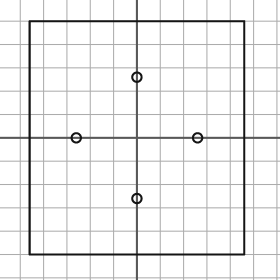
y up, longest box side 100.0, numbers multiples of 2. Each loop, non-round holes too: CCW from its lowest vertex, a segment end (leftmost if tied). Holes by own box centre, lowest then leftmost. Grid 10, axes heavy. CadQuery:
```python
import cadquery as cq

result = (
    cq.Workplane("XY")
    .moveTo(-46.0, -50.0)
    .lineTo(46.0, -50.0)
    .lineTo(46.0, 50.0)
    .lineTo(-46.0, 50.0)
    .close()
    .moveTo(0.0, -26.0)
    .circle(2.0)
    .moveTo(-26.0, 0.0)
    .circle(2.0)
    .moveTo(26.0, 0.0)
    .circle(2.0)
    .moveTo(0.0, 26.0)
    .circle(2.0)
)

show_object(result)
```